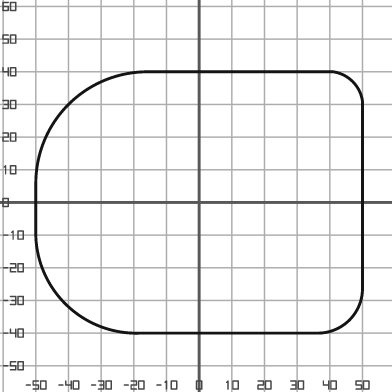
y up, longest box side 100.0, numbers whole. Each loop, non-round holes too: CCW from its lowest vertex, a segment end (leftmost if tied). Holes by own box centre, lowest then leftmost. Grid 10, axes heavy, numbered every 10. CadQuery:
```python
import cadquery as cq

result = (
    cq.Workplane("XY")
    .moveTo(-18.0, -40.0)
    .lineTo(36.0, -40.0)
    .threePointArc((46.0, -36.0), (50.0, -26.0))
    .lineTo(50.0, 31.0)
    .threePointArc((47.0, 37.0), (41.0, 40.0))
    .lineTo(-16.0, 40.0)
    .threePointArc((-40.0, 30.0), (-50.0, 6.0))
    .lineTo(-50.0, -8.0)
    .threePointArc((-41.0, -31.0), (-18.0, -40.0))
    .close()
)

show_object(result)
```